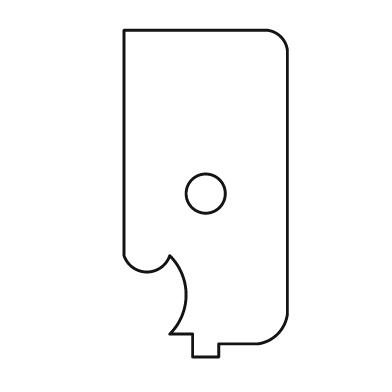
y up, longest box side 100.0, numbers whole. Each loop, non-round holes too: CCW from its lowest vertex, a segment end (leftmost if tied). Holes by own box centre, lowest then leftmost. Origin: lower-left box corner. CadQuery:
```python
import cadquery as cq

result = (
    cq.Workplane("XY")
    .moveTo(21.0, 0.0)
    .lineTo(29.0, 0.0)
    .lineTo(29.0, 4.0)
    .lineTo(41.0, 4.0)
    .threePointArc((47.0, 7.0), (50.0, 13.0))
    .lineTo(50.0, 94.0)
    .threePointArc((48.0, 98.0), (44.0, 100.0))
    .lineTo(0.0, 100.0)
    .lineTo(0.0, 31.0)
    .threePointArc((7.0, 26.0), (14.0, 31.0))
    .threePointArc((19.0, 19.0), (14.0, 7.0))
    .lineTo(21.0, 7.0)
    .close()
    .moveTo(25.0, 50.0)
    .circle(6.0)
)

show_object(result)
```